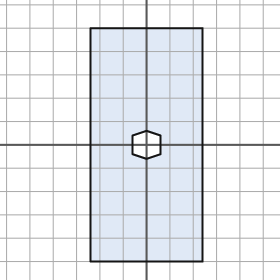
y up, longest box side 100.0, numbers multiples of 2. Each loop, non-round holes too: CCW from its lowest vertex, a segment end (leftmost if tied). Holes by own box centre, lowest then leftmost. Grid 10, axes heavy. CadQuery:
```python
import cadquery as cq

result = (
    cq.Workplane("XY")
    .moveTo(-24.0, -50.0)
    .lineTo(24.0, -50.0)
    .lineTo(24.0, 50.0)
    .lineTo(-24.0, 50.0)
    .close()
    .moveTo(0.0, -6.0)
    .lineTo(6.0, -4.0)
    .lineTo(6.0, 4.0)
    .lineTo(0.0, 6.0)
    .lineTo(-6.0, 4.0)
    .lineTo(-6.0, -4.0)
    .close()
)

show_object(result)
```